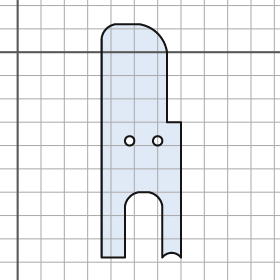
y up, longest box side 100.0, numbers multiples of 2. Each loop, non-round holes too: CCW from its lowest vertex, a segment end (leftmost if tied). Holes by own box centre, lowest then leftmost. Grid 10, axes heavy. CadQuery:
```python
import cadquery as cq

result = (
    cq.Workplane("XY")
    .moveTo(36.0, -88.0)
    .lineTo(46.0, -88.0)
    .lineTo(46.0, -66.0)
    .threePointArc((48.0, -62.0), (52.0, -60.0))
    .lineTo(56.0, -60.0)
    .threePointArc((60.0, -62.0), (62.0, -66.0))
    .lineTo(62.0, -88.0)
    .threePointArc((66.0, -86.0), (70.0, -88.0))
    .lineTo(70.0, -30.0)
    .lineTo(64.0, -30.0)
    .lineTo(64.0, 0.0)
    .threePointArc((60.0, 8.0), (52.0, 12.0))
    .lineTo(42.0, 12.0)
    .threePointArc((38.0, 10.0), (36.0, 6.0))
    .close()
    .moveTo(48.0, -38.0)
    .circle(2.0)
    .moveTo(60.0, -38.0)
    .circle(2.0)
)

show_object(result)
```